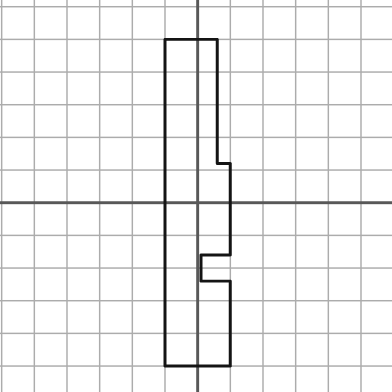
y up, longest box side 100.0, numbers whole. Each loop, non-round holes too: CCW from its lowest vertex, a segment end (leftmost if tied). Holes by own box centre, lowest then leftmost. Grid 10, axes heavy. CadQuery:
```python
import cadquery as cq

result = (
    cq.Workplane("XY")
    .moveTo(-10.0, -50.0)
    .lineTo(10.0, -50.0)
    .lineTo(10.0, -24.0)
    .lineTo(1.0, -24.0)
    .lineTo(1.0, -16.0)
    .lineTo(10.0, -16.0)
    .lineTo(10.0, 12.0)
    .lineTo(6.0, 12.0)
    .lineTo(6.0, 50.0)
    .lineTo(-10.0, 50.0)
    .close()
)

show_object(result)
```